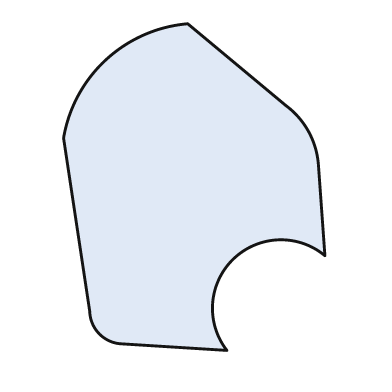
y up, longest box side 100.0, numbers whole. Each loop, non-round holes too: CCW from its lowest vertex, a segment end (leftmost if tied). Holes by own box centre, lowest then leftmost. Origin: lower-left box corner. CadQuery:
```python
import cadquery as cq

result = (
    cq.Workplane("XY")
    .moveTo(50.0, 0.0)
    .threePointArc((52.0, 28.0), (80.0, 29.0))
    .lineTo(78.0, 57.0)
    .threePointArc((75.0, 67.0), (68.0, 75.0))
    .lineTo(38.0, 100.0)
    .threePointArc((13.0, 89.0), (0.0, 65.0))
    .lineTo(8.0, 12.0)
    .threePointArc((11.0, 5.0), (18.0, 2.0))
    .close()
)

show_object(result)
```